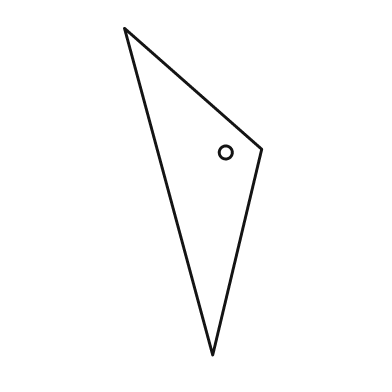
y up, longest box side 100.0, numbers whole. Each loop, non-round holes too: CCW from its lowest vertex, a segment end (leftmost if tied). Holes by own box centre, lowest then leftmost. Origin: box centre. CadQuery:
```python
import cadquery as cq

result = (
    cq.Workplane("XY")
    .moveTo(6.0, -50.0)
    .lineTo(21.0, 13.0)
    .lineTo(-21.0, 50.0)
    .close()
    .moveTo(10.0, 12.0)
    .circle(2.0)
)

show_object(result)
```